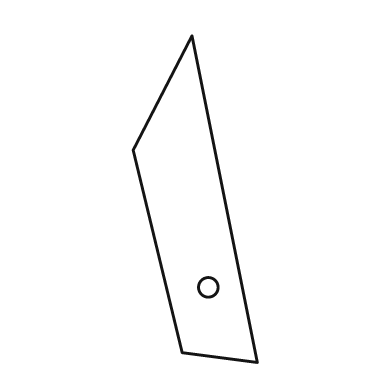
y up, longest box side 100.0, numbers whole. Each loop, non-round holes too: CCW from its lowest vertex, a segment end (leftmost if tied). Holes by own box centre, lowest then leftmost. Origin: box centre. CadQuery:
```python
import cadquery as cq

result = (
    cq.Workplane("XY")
    .moveTo(19.0, -50.0)
    .lineTo(-1.0, 50.0)
    .lineTo(-19.0, 15.0)
    .lineTo(-4.0, -47.0)
    .close()
    .moveTo(4.0, -27.0)
    .circle(3.0)
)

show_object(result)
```